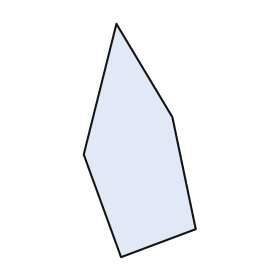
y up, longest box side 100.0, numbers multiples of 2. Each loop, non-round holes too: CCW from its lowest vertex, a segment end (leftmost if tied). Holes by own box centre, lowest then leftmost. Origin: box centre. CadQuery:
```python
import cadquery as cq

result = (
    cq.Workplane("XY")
    .moveTo(-8.0, -50.0)
    .lineTo(24.0, -38.0)
    .lineTo(14.0, 10.0)
    .lineTo(-10.0, 50.0)
    .lineTo(-24.0, -6.0)
    .close()
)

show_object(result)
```